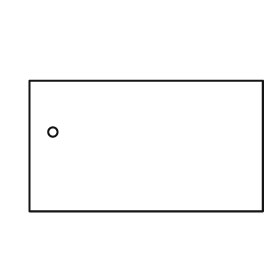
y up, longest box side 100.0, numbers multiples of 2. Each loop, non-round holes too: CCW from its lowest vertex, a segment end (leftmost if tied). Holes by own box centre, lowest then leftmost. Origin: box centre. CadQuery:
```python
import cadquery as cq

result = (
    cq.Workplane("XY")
    .moveTo(-50.0, -28.0)
    .lineTo(50.0, -28.0)
    .lineTo(50.0, 28.0)
    .lineTo(-50.0, 28.0)
    .close()
    .moveTo(-40.0, 6.0)
    .circle(2.0)
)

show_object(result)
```